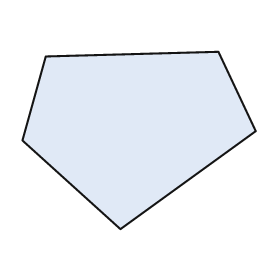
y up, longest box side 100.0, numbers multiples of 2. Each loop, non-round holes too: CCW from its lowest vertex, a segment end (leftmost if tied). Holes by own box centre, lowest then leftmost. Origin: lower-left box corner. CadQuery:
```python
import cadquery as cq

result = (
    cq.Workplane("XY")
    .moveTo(42.0, 0.0)
    .lineTo(100.0, 42.0)
    .lineTo(84.0, 76.0)
    .lineTo(10.0, 74.0)
    .lineTo(0.0, 38.0)
    .close()
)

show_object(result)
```